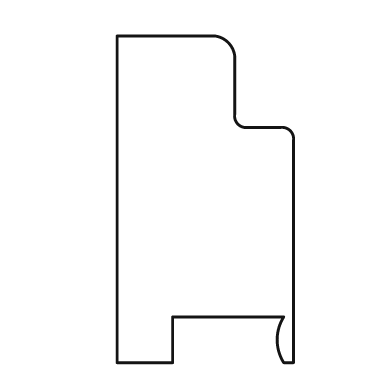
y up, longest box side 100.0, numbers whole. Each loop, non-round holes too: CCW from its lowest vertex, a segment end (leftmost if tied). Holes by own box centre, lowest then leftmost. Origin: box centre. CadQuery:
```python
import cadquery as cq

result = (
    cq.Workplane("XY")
    .moveTo(-27.0, -50.0)
    .lineTo(-10.0, -50.0)
    .lineTo(-10.0, -36.0)
    .lineTo(24.0, -36.0)
    .threePointArc((22.0, -43.0), (24.0, -50.0))
    .lineTo(27.0, -50.0)
    .lineTo(27.0, 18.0)
    .threePointArc((26.0, 21.0), (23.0, 22.0))
    .lineTo(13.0, 22.0)
    .threePointArc((10.0, 23.0), (9.0, 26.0))
    .lineTo(9.0, 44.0)
    .threePointArc((7.0, 48.0), (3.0, 50.0))
    .lineTo(-27.0, 50.0)
    .close()
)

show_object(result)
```